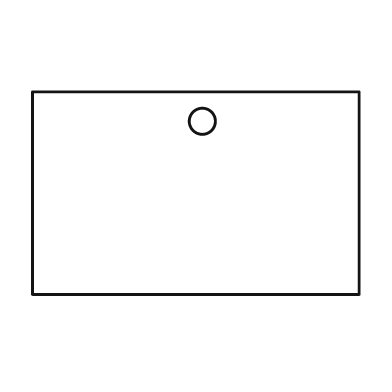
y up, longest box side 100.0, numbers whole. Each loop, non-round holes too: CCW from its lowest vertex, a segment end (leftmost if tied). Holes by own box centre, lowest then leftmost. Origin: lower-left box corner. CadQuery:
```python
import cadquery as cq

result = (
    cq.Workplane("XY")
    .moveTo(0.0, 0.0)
    .lineTo(100.0, 0.0)
    .lineTo(100.0, 62.0)
    .lineTo(0.0, 62.0)
    .close()
    .moveTo(52.0, 53.0)
    .circle(4.0)
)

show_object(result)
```